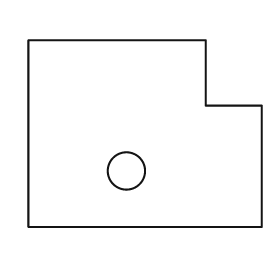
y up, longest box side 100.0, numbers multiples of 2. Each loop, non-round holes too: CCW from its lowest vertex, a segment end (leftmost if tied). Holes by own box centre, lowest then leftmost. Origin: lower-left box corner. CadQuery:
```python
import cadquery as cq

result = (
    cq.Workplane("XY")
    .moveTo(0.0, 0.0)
    .lineTo(100.0, 0.0)
    .lineTo(100.0, 52.0)
    .lineTo(76.0, 52.0)
    .lineTo(76.0, 80.0)
    .lineTo(0.0, 80.0)
    .close()
    .moveTo(42.0, 24.0)
    .circle(8.0)
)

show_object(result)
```